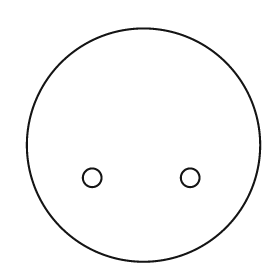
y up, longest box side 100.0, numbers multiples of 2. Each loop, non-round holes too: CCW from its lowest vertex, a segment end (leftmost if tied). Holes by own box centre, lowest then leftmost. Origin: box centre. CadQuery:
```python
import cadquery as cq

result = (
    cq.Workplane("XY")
    .moveTo(0.0, 0.0)
    .circle(50.0)
    .moveTo(-22.0, -14.0)
    .circle(4.0)
    .moveTo(20.0, -14.0)
    .circle(4.0)
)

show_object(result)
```